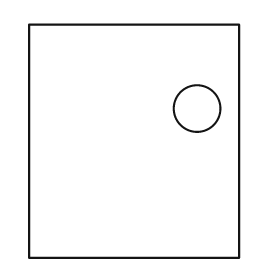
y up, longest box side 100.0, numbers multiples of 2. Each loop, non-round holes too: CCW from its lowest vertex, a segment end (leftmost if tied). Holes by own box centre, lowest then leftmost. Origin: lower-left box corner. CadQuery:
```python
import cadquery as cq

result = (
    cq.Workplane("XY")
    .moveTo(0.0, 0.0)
    .lineTo(90.0, 0.0)
    .lineTo(90.0, 100.0)
    .lineTo(0.0, 100.0)
    .close()
    .moveTo(72.0, 64.0)
    .circle(10.0)
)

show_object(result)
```